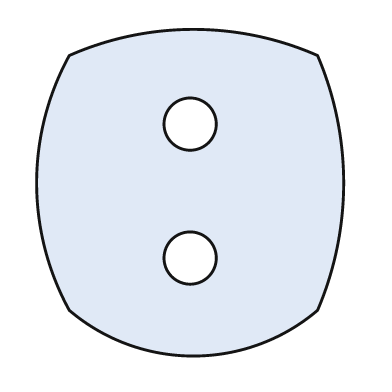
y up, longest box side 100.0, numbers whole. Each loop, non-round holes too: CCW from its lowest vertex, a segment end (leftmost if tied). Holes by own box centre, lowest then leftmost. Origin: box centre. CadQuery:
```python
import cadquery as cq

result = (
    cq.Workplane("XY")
    .moveTo(-37.0, -36.0)
    .threePointArc((1.0, -50.0), (39.0, -36.0))
    .threePointArc((47.0, 3.0), (39.0, 42.0))
    .threePointArc((1.0, 50.0), (-37.0, 42.0))
    .threePointArc((-47.0, 3.0), (-37.0, -36.0))
    .close()
    .moveTo(0.0, -20.0)
    .circle(8.0)
    .moveTo(0.0, 21.0)
    .circle(8.0)
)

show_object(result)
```